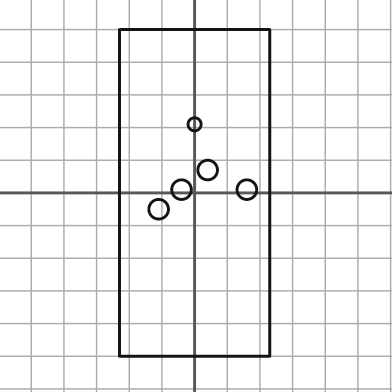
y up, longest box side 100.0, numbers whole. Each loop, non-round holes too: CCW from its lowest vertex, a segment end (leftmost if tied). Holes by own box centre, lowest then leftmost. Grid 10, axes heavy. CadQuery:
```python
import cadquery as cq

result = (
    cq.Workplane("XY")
    .moveTo(-23.0, -50.0)
    .lineTo(23.0, -50.0)
    .lineTo(23.0, 50.0)
    .lineTo(-23.0, 50.0)
    .close()
    .moveTo(-11.0, -5.0)
    .circle(3.0)
    .moveTo(-4.0, 1.0)
    .circle(3.0)
    .moveTo(16.0, 1.0)
    .circle(3.0)
    .moveTo(4.0, 7.0)
    .circle(3.0)
    .moveTo(0.0, 21.0)
    .circle(2.0)
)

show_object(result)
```